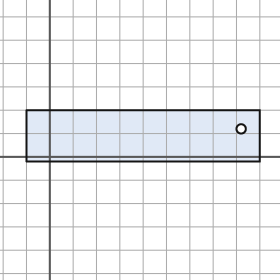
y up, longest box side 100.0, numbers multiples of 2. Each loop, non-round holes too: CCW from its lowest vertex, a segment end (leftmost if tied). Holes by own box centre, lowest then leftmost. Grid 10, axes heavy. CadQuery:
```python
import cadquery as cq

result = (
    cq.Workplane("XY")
    .moveTo(-10.0, -2.0)
    .lineTo(90.0, -2.0)
    .lineTo(90.0, 20.0)
    .lineTo(-10.0, 20.0)
    .close()
    .moveTo(82.0, 12.0)
    .circle(2.0)
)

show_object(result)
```